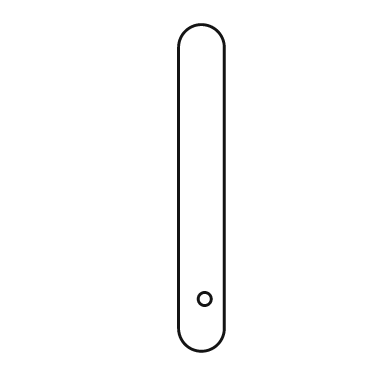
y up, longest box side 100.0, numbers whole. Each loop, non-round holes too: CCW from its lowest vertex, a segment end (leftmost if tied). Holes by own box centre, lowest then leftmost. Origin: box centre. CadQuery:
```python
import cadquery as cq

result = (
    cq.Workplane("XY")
    .moveTo(-7.0, -43.0)
    .threePointArc((0.0, -50.0), (7.0, -43.0))
    .lineTo(7.0, 43.0)
    .threePointArc((0.0, 50.0), (-7.0, 43.0))
    .close()
    .moveTo(1.0, -34.0)
    .circle(2.0)
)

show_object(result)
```